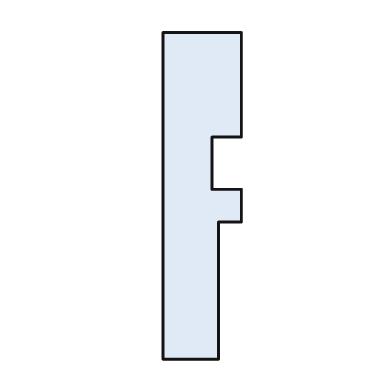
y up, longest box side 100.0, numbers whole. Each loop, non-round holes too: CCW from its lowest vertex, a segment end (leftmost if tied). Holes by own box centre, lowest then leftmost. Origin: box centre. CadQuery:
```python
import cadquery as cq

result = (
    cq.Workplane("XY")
    .moveTo(-12.0, -50.0)
    .lineTo(5.0, -50.0)
    .lineTo(5.0, -8.0)
    .lineTo(12.0, -8.0)
    .lineTo(12.0, 2.0)
    .lineTo(3.0, 2.0)
    .lineTo(3.0, 18.0)
    .lineTo(12.0, 18.0)
    .lineTo(12.0, 50.0)
    .lineTo(-12.0, 50.0)
    .close()
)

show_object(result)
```